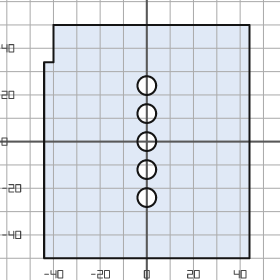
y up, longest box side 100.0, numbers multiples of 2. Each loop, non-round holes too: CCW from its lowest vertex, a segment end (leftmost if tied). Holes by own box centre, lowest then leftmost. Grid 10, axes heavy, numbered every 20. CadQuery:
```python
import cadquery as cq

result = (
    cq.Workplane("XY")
    .moveTo(-44.0, -50.0)
    .lineTo(44.0, -50.0)
    .lineTo(44.0, 50.0)
    .lineTo(-40.0, 50.0)
    .lineTo(-40.0, 34.0)
    .lineTo(-44.0, 34.0)
    .close()
    .moveTo(0.0, -24.0)
    .circle(4.0)
    .moveTo(0.0, -12.0)
    .circle(4.0)
    .moveTo(0.0, 0.0)
    .circle(4.0)
    .moveTo(0.0, 12.0)
    .circle(4.0)
    .moveTo(0.0, 24.0)
    .circle(4.0)
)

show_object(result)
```